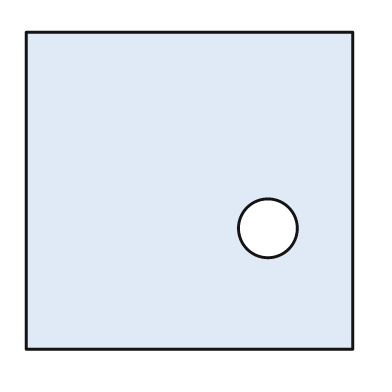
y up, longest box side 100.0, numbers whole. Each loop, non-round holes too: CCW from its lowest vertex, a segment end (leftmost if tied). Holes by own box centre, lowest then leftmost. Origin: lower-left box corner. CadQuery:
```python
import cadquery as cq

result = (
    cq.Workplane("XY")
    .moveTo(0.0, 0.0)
    .lineTo(100.0, 0.0)
    .lineTo(100.0, 97.0)
    .lineTo(0.0, 97.0)
    .close()
    .moveTo(74.0, 37.0)
    .circle(9.0)
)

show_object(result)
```